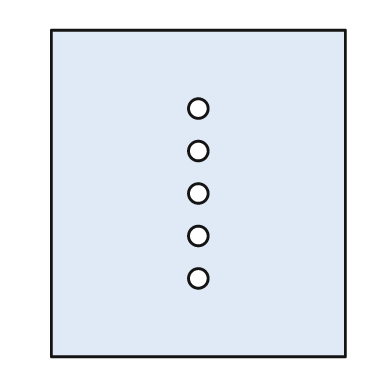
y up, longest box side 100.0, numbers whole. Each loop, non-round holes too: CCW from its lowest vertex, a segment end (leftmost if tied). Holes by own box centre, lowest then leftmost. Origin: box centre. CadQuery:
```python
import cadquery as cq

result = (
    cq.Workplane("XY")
    .moveTo(-45.0, -50.0)
    .lineTo(45.0, -50.0)
    .lineTo(45.0, 50.0)
    .lineTo(-45.0, 50.0)
    .close()
    .moveTo(0.0, -26.0)
    .circle(3.0)
    .moveTo(0.0, -13.0)
    .circle(3.0)
    .moveTo(0.0, 0.0)
    .circle(3.0)
    .moveTo(0.0, 13.0)
    .circle(3.0)
    .moveTo(0.0, 26.0)
    .circle(3.0)
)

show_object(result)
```